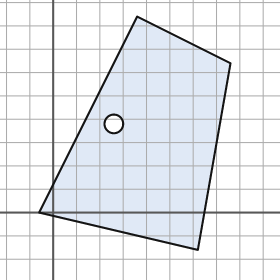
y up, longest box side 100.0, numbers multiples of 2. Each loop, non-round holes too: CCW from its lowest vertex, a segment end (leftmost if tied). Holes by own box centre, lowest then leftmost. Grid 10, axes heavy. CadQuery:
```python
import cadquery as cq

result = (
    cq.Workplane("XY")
    .moveTo(62.0, -16.0)
    .lineTo(76.0, 64.0)
    .lineTo(36.0, 84.0)
    .lineTo(-6.0, 0.0)
    .close()
    .moveTo(26.0, 38.0)
    .circle(4.0)
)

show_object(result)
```